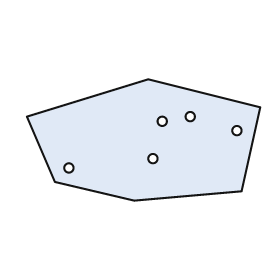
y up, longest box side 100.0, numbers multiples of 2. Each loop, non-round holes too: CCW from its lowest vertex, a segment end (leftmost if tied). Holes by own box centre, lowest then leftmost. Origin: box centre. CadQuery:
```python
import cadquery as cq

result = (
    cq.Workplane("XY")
    .moveTo(-4.0, -26.0)
    .lineTo(42.0, -22.0)
    .lineTo(50.0, 14.0)
    .lineTo(2.0, 26.0)
    .lineTo(-50.0, 10.0)
    .lineTo(-38.0, -18.0)
    .close()
    .moveTo(-32.0, -12.0)
    .circle(2.0)
    .moveTo(4.0, -8.0)
    .circle(2.0)
    .moveTo(40.0, 4.0)
    .circle(2.0)
    .moveTo(8.0, 8.0)
    .circle(2.0)
    .moveTo(20.0, 10.0)
    .circle(2.0)
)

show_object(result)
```